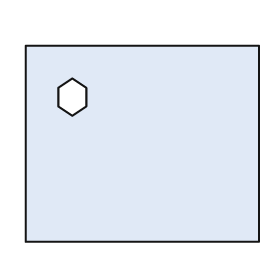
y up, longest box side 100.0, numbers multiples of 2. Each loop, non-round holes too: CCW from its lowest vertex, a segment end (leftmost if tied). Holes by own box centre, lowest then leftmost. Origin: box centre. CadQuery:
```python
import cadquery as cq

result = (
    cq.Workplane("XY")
    .moveTo(-50.0, -42.0)
    .lineTo(50.0, -42.0)
    .lineTo(50.0, 42.0)
    .lineTo(-50.0, 42.0)
    .close()
    .moveTo(-30.0, 12.0)
    .lineTo(-24.0, 16.0)
    .lineTo(-24.0, 24.0)
    .lineTo(-30.0, 28.0)
    .lineTo(-36.0, 24.0)
    .lineTo(-36.0, 16.0)
    .close()
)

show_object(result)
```